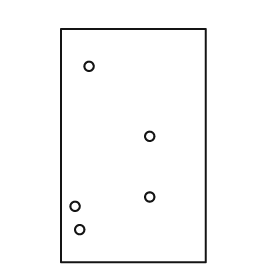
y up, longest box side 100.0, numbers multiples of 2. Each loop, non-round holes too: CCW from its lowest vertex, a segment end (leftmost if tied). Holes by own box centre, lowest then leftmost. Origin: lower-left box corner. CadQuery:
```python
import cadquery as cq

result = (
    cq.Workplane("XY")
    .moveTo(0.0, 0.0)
    .lineTo(62.0, 0.0)
    .lineTo(62.0, 100.0)
    .lineTo(0.0, 100.0)
    .close()
    .moveTo(8.0, 14.0)
    .circle(2.0)
    .moveTo(6.0, 24.0)
    .circle(2.0)
    .moveTo(38.0, 28.0)
    .circle(2.0)
    .moveTo(38.0, 54.0)
    .circle(2.0)
    .moveTo(12.0, 84.0)
    .circle(2.0)
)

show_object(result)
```